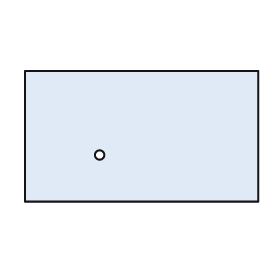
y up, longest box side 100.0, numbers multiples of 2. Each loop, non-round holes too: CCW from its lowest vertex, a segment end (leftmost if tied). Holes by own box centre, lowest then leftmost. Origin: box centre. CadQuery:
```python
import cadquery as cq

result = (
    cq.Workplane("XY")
    .moveTo(-50.0, -28.0)
    .lineTo(50.0, -28.0)
    .lineTo(50.0, 28.0)
    .lineTo(-50.0, 28.0)
    .close()
    .moveTo(-18.0, -8.0)
    .circle(2.0)
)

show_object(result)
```